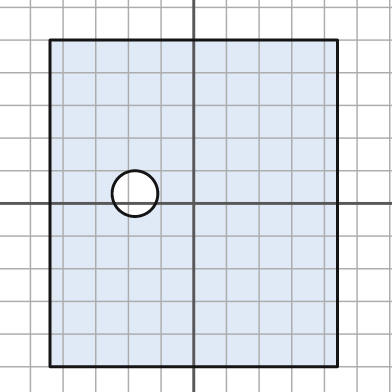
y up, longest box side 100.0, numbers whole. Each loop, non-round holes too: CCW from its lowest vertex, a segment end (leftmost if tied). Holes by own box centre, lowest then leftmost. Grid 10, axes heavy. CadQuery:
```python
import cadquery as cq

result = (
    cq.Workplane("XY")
    .moveTo(-44.0, -50.0)
    .lineTo(44.0, -50.0)
    .lineTo(44.0, 50.0)
    .lineTo(-44.0, 50.0)
    .close()
    .moveTo(-18.0, 3.0)
    .circle(7.0)
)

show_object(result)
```